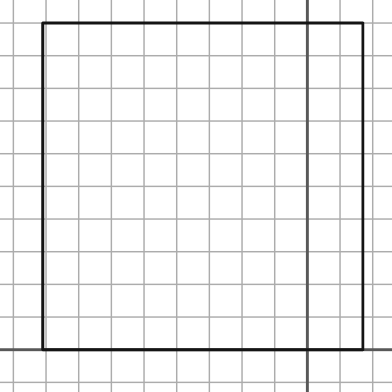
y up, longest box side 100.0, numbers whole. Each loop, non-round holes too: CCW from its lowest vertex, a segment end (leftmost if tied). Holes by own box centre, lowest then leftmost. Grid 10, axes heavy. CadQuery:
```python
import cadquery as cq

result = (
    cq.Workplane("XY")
    .moveTo(-81.0, 0.0)
    .lineTo(17.0, 0.0)
    .lineTo(17.0, 100.0)
    .lineTo(-81.0, 100.0)
    .close()
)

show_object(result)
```